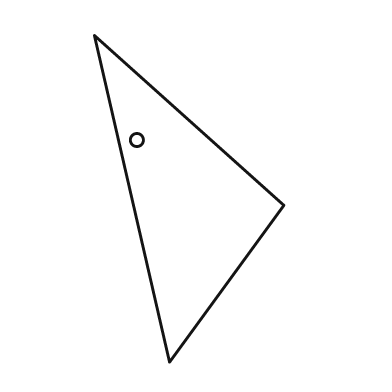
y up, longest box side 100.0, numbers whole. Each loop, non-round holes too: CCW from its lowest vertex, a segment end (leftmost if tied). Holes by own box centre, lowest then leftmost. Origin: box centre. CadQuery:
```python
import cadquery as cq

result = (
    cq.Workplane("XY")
    .moveTo(-6.0, -50.0)
    .lineTo(29.0, -2.0)
    .lineTo(-29.0, 50.0)
    .close()
    .moveTo(-16.0, 18.0)
    .circle(2.0)
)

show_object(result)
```